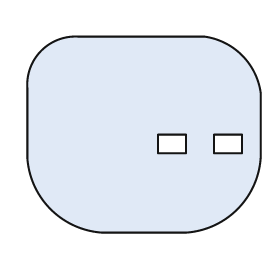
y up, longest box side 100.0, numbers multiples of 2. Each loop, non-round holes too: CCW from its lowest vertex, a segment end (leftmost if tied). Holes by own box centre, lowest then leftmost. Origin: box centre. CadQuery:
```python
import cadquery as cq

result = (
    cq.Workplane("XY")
    .moveTo(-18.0, -42.0)
    .lineTo(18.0, -42.0)
    .threePointArc((40.0, -32.0), (50.0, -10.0))
    .lineTo(50.0, 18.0)
    .threePointArc((42.0, 34.0), (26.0, 42.0))
    .lineTo(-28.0, 42.0)
    .threePointArc((-44.0, 36.0), (-50.0, 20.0))
    .lineTo(-50.0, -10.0)
    .threePointArc((-40.0, -32.0), (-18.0, -42.0))
    .close()
    .moveTo(6.0, -8.0)
    .lineTo(18.0, -8.0)
    .lineTo(18.0, 0.0)
    .lineTo(6.0, 0.0)
    .close()
    .moveTo(30.0, -8.0)
    .lineTo(42.0, -8.0)
    .lineTo(42.0, 0.0)
    .lineTo(30.0, 0.0)
    .close()
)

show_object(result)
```